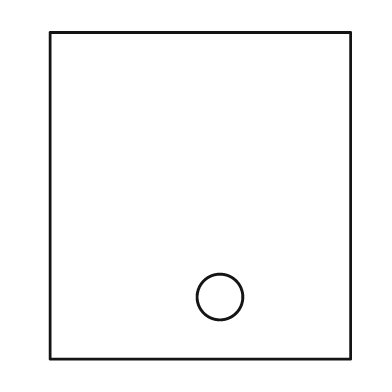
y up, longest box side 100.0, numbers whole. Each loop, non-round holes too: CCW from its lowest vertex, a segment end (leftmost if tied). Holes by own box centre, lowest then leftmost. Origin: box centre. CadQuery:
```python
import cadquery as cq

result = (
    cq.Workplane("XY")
    .moveTo(-46.0, -50.0)
    .lineTo(46.0, -50.0)
    .lineTo(46.0, 50.0)
    .lineTo(-46.0, 50.0)
    .close()
    .moveTo(6.0, -31.0)
    .circle(7.0)
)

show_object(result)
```